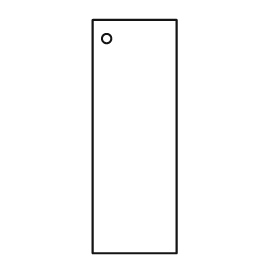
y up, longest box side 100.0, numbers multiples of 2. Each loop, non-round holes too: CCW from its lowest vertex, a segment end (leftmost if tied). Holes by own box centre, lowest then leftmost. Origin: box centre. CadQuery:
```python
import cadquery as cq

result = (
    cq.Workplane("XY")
    .moveTo(-18.0, -50.0)
    .lineTo(18.0, -50.0)
    .lineTo(18.0, 50.0)
    .lineTo(-18.0, 50.0)
    .close()
    .moveTo(-12.0, 42.0)
    .circle(2.0)
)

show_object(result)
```